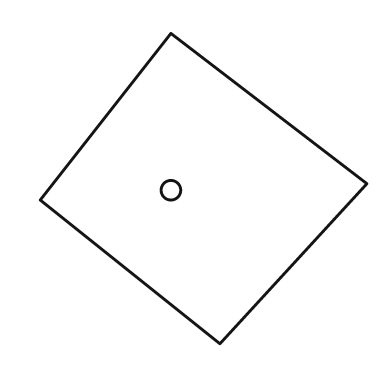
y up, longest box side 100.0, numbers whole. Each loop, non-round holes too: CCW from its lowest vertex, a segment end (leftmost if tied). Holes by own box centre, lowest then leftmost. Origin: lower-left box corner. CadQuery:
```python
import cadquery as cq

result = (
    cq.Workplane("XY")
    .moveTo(55.0, 0.0)
    .lineTo(100.0, 49.0)
    .lineTo(40.0, 95.0)
    .lineTo(0.0, 44.0)
    .close()
    .moveTo(40.0, 47.0)
    .circle(3.0)
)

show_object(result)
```